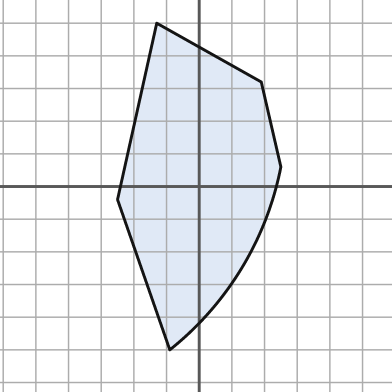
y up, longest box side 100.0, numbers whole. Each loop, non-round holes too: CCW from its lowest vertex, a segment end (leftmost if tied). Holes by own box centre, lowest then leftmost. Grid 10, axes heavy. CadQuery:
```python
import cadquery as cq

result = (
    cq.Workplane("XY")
    .moveTo(-9.0, -50.0)
    .threePointArc((13.0, -25.0), (25.0, 6.0))
    .lineTo(19.0, 32.0)
    .lineTo(-13.0, 50.0)
    .lineTo(-25.0, -4.0)
    .close()
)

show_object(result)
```